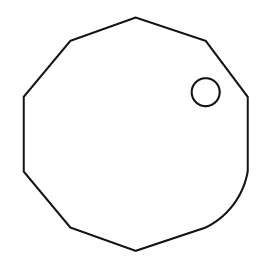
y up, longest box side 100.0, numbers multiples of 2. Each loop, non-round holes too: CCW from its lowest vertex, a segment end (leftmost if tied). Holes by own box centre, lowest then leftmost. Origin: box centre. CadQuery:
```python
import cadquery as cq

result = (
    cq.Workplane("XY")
    .moveTo(0.0, -50.0)
    .lineTo(30.0, -40.0)
    .threePointArc((42.0, -30.0), (48.0, -16.0))
    .lineTo(48.0, 16.0)
    .lineTo(30.0, 40.0)
    .lineTo(0.0, 50.0)
    .lineTo(-28.0, 40.0)
    .lineTo(-48.0, 16.0)
    .lineTo(-48.0, -16.0)
    .lineTo(-28.0, -40.0)
    .close()
    .moveTo(30.0, 18.0)
    .circle(6.0)
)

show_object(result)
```